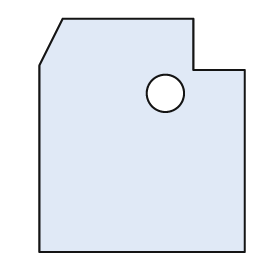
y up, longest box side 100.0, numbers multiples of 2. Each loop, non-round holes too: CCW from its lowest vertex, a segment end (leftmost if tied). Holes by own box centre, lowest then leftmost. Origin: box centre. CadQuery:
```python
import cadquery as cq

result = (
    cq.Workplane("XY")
    .moveTo(-44.0, -50.0)
    .lineTo(44.0, -50.0)
    .lineTo(44.0, 28.0)
    .lineTo(22.0, 28.0)
    .lineTo(22.0, 50.0)
    .lineTo(-34.0, 50.0)
    .lineTo(-44.0, 30.0)
    .close()
    .moveTo(10.0, 18.0)
    .circle(8.0)
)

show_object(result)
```